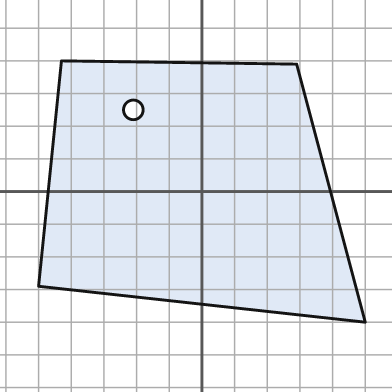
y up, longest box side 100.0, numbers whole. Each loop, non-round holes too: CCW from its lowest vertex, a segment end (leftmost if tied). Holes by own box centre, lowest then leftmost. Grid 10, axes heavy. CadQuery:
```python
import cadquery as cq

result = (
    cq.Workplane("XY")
    .moveTo(50.0, -40.0)
    .lineTo(29.0, 39.0)
    .lineTo(-43.0, 40.0)
    .lineTo(-50.0, -29.0)
    .close()
    .moveTo(-21.0, 25.0)
    .circle(3.0)
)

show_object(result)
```